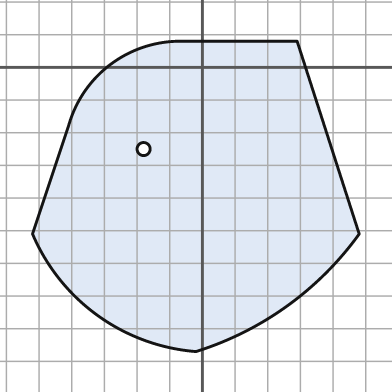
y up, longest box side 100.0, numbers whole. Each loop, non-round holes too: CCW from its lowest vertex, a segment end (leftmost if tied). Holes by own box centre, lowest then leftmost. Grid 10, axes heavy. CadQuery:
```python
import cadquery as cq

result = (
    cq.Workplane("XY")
    .moveTo(-2.0, -87.0)
    .threePointArc((26.0, -73.0), (48.0, -51.0))
    .lineTo(29.0, 8.0)
    .lineTo(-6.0, 8.0)
    .threePointArc((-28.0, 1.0), (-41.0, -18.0))
    .lineTo(-52.0, -51.0)
    .threePointArc((-32.0, -76.0), (-2.0, -87.0))
    .close()
    .moveTo(-18.0, -25.0)
    .circle(2.0)
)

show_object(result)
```